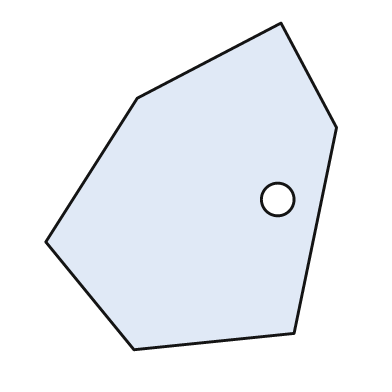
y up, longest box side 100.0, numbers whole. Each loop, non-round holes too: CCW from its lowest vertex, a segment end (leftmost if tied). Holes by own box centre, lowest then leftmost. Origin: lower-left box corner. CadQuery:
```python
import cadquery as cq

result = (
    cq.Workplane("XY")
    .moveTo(27.0, 0.0)
    .lineTo(76.0, 5.0)
    .lineTo(89.0, 68.0)
    .lineTo(72.0, 100.0)
    .lineTo(28.0, 77.0)
    .lineTo(0.0, 33.0)
    .close()
    .moveTo(71.0, 46.0)
    .circle(5.0)
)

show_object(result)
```